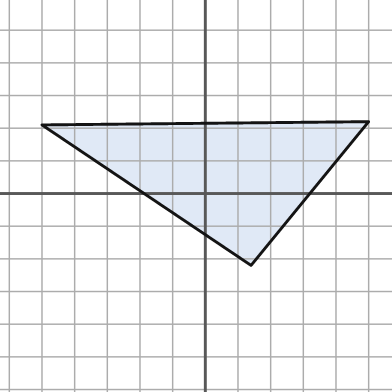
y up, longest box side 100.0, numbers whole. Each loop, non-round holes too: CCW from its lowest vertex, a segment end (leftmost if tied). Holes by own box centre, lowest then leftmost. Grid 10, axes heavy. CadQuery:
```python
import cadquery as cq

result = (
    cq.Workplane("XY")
    .moveTo(14.0, -22.0)
    .lineTo(50.0, 22.0)
    .lineTo(-50.0, 21.0)
    .close()
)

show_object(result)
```